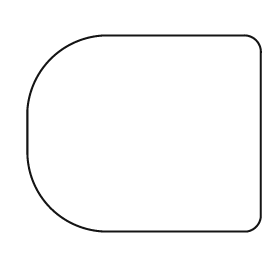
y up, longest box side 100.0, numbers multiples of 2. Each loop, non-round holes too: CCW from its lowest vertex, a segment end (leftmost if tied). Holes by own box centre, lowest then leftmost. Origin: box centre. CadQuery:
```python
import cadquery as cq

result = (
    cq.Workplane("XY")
    .moveTo(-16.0, -42.0)
    .lineTo(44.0, -42.0)
    .threePointArc((48.0, -40.0), (50.0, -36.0))
    .lineTo(50.0, 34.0)
    .threePointArc((48.0, 40.0), (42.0, 42.0))
    .lineTo(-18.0, 42.0)
    .threePointArc((-40.0, 32.0), (-50.0, 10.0))
    .lineTo(-50.0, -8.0)
    .threePointArc((-40.0, -32.0), (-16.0, -42.0))
    .close()
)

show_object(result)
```